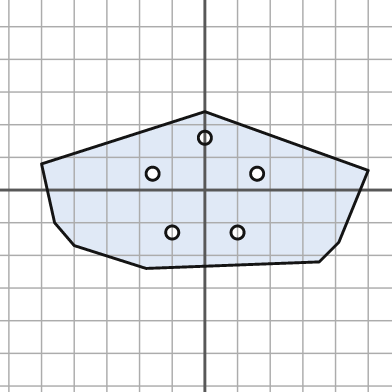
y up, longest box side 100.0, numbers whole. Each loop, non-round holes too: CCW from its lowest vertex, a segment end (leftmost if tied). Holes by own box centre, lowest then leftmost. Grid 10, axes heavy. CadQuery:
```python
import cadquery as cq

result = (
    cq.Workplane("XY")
    .moveTo(-18.0, -24.0)
    .lineTo(35.0, -22.0)
    .lineTo(41.0, -16.0)
    .lineTo(50.0, 6.0)
    .lineTo(0.0, 24.0)
    .lineTo(-50.0, 8.0)
    .lineTo(-46.0, -10.0)
    .lineTo(-40.0, -17.0)
    .close()
    .moveTo(-10.0, -13.0)
    .circle(2.0)
    .moveTo(10.0, -13.0)
    .circle(2.0)
    .moveTo(-16.0, 5.0)
    .circle(2.0)
    .moveTo(16.0, 5.0)
    .circle(2.0)
    .moveTo(0.0, 16.0)
    .circle(2.0)
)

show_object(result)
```